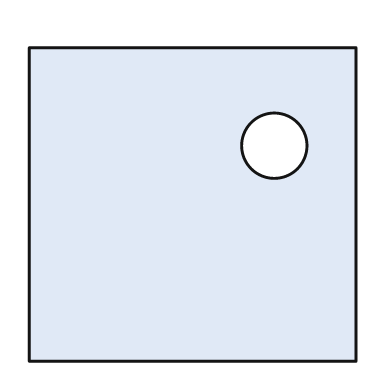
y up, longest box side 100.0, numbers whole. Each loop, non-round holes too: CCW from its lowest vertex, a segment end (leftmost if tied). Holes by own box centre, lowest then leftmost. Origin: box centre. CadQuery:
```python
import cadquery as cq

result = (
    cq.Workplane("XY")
    .moveTo(-50.0, -48.0)
    .lineTo(50.0, -48.0)
    .lineTo(50.0, 48.0)
    .lineTo(-50.0, 48.0)
    .close()
    .moveTo(25.0, 18.0)
    .circle(10.0)
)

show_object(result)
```